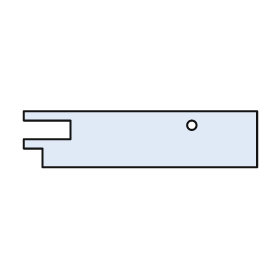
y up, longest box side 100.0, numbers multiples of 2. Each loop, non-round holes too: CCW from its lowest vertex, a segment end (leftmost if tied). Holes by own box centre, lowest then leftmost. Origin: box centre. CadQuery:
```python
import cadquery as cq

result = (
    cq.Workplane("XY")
    .moveTo(-42.0, -12.0)
    .lineTo(50.0, -12.0)
    .lineTo(50.0, 12.0)
    .lineTo(-50.0, 12.0)
    .lineTo(-50.0, 8.0)
    .lineTo(-30.0, 8.0)
    .lineTo(-30.0, 0.0)
    .lineTo(-50.0, 0.0)
    .lineTo(-50.0, -4.0)
    .lineTo(-42.0, -4.0)
    .close()
    .moveTo(22.0, 6.0)
    .circle(2.0)
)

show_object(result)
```